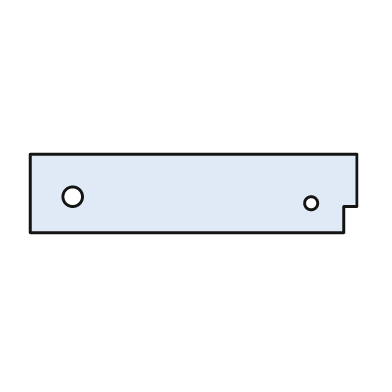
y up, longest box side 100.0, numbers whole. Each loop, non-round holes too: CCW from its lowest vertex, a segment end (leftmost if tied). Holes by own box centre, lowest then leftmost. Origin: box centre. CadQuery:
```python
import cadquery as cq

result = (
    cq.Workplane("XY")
    .moveTo(-50.0, -12.0)
    .lineTo(46.0, -12.0)
    .lineTo(46.0, -4.0)
    .lineTo(50.0, -4.0)
    .lineTo(50.0, 12.0)
    .lineTo(-50.0, 12.0)
    .close()
    .moveTo(36.0, -3.0)
    .circle(2.0)
    .moveTo(-37.0, -1.0)
    .circle(3.0)
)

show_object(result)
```